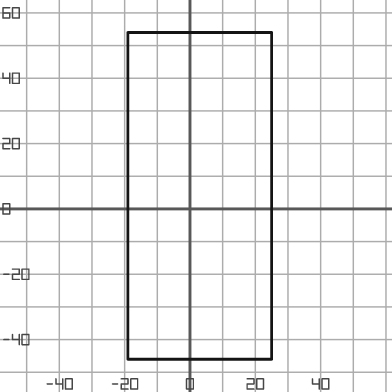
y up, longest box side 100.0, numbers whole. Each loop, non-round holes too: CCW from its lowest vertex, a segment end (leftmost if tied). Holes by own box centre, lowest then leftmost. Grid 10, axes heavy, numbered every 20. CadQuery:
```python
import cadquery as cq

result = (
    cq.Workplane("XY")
    .moveTo(-19.0, -46.0)
    .lineTo(25.0, -46.0)
    .lineTo(25.0, 54.0)
    .lineTo(-19.0, 54.0)
    .close()
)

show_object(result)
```